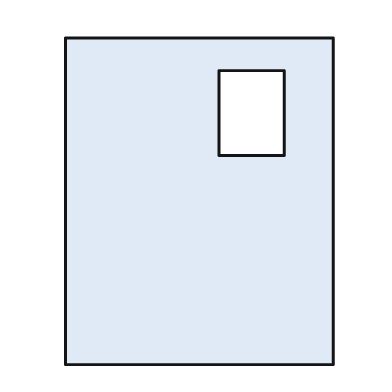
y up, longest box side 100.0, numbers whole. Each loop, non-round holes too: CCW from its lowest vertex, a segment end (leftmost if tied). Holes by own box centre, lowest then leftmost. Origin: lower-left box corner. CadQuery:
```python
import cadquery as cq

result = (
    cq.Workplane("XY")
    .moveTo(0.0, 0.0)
    .lineTo(82.0, 0.0)
    .lineTo(82.0, 100.0)
    .lineTo(0.0, 100.0)
    .close()
    .moveTo(47.0, 64.0)
    .lineTo(67.0, 64.0)
    .lineTo(67.0, 90.0)
    .lineTo(47.0, 90.0)
    .close()
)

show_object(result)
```